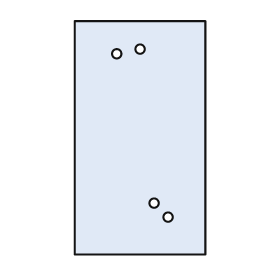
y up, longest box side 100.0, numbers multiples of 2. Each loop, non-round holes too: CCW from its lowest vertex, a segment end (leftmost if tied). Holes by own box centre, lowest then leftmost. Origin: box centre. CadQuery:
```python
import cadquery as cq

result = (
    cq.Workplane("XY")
    .moveTo(-28.0, -50.0)
    .lineTo(28.0, -50.0)
    .lineTo(28.0, 50.0)
    .lineTo(-28.0, 50.0)
    .close()
    .moveTo(12.0, -34.0)
    .circle(2.0)
    .moveTo(6.0, -28.0)
    .circle(2.0)
    .moveTo(-10.0, 36.0)
    .circle(2.0)
    .moveTo(0.0, 38.0)
    .circle(2.0)
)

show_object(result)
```